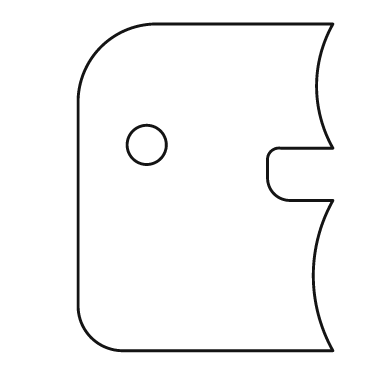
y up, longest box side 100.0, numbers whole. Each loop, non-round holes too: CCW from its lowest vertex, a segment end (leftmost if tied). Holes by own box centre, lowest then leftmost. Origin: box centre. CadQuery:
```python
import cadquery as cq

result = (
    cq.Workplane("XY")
    .moveTo(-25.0, -50.0)
    .lineTo(39.0, -50.0)
    .threePointArc((33.0, -27.0), (39.0, -4.0))
    .lineTo(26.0, -4.0)
    .threePointArc((21.0, -2.0), (19.0, 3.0))
    .lineTo(19.0, 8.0)
    .threePointArc((20.0, 11.0), (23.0, 12.0))
    .lineTo(39.0, 12.0)
    .threePointArc((34.0, 31.0), (39.0, 50.0))
    .lineTo(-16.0, 50.0)
    .threePointArc((-32.0, 43.0), (-39.0, 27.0))
    .lineTo(-39.0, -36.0)
    .threePointArc((-35.0, -46.0), (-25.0, -50.0))
    .close()
    .moveTo(-18.0, 13.0)
    .circle(6.0)
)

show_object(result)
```